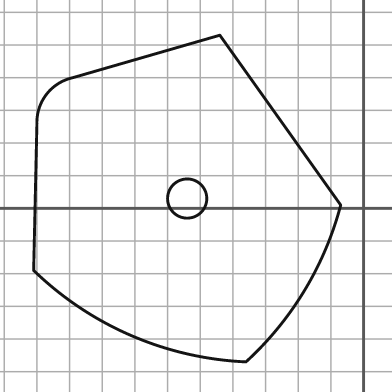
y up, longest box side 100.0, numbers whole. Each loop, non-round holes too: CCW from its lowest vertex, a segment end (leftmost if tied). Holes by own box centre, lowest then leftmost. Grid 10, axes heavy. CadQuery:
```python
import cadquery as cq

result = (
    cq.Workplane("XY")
    .moveTo(-36.0, -47.0)
    .threePointArc((-18.0, -25.0), (-7.0, 1.0))
    .lineTo(-44.0, 53.0)
    .lineTo(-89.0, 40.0)
    .threePointArc((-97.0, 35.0), (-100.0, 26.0))
    .lineTo(-101.0, -19.0)
    .threePointArc((-71.0, -39.0), (-36.0, -47.0))
    .close()
    .moveTo(-54.0, 3.0)
    .circle(6.0)
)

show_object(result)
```